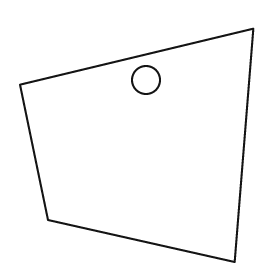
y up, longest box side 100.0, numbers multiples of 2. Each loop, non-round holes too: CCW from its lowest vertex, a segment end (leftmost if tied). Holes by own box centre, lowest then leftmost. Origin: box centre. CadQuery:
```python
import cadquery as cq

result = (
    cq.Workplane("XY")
    .moveTo(42.0, -50.0)
    .lineTo(50.0, 50.0)
    .lineTo(-50.0, 26.0)
    .lineTo(-38.0, -32.0)
    .close()
    .moveTo(4.0, 28.0)
    .circle(6.0)
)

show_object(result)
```